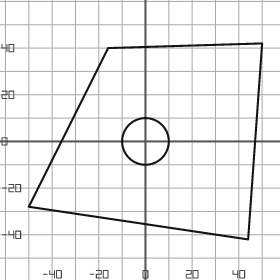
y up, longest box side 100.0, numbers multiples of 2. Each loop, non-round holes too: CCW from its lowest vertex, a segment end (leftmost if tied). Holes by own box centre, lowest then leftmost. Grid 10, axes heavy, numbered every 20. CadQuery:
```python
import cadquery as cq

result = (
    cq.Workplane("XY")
    .moveTo(44.0, -42.0)
    .lineTo(50.0, 42.0)
    .lineTo(-16.0, 40.0)
    .lineTo(-50.0, -28.0)
    .close()
    .moveTo(0.0, 0.0)
    .circle(10.0)
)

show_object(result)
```